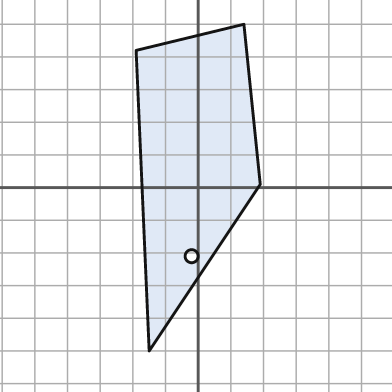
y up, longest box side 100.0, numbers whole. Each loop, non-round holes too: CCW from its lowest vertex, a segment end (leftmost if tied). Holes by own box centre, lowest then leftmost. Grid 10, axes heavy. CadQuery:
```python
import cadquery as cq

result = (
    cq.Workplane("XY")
    .moveTo(-15.0, -50.0)
    .lineTo(19.0, 1.0)
    .lineTo(14.0, 50.0)
    .lineTo(-19.0, 42.0)
    .close()
    .moveTo(-2.0, -21.0)
    .circle(2.0)
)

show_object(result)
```